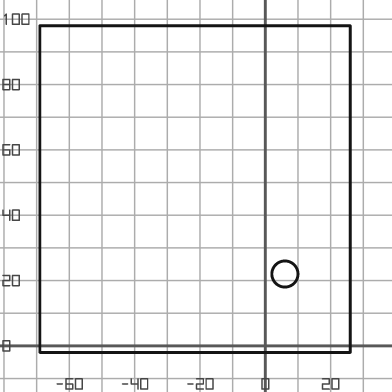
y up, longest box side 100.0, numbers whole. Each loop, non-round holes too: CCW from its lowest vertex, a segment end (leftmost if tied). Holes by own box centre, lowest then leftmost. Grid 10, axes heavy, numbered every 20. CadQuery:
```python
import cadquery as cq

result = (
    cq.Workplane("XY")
    .moveTo(-69.0, -2.0)
    .lineTo(26.0, -2.0)
    .lineTo(26.0, 98.0)
    .lineTo(-69.0, 98.0)
    .close()
    .moveTo(6.0, 22.0)
    .circle(4.0)
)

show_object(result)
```